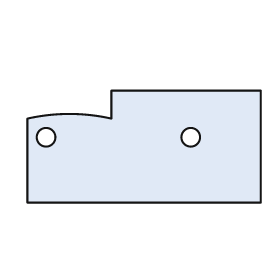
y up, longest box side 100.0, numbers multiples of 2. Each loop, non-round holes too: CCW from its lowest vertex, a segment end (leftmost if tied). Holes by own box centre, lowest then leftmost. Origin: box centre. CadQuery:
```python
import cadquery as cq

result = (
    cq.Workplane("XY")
    .moveTo(-50.0, -24.0)
    .lineTo(50.0, -24.0)
    .lineTo(50.0, 24.0)
    .lineTo(-14.0, 24.0)
    .lineTo(-14.0, 12.0)
    .threePointArc((-32.0, 14.0), (-50.0, 12.0))
    .close()
    .moveTo(-42.0, 4.0)
    .circle(4.0)
    .moveTo(20.0, 4.0)
    .circle(4.0)
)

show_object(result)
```